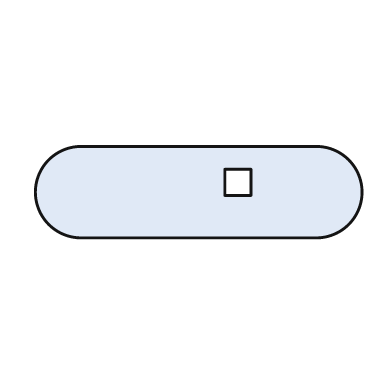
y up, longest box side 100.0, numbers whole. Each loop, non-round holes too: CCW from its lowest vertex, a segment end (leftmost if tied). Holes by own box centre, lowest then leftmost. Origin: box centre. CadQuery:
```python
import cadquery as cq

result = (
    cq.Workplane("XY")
    .moveTo(-36.0, -14.0)
    .lineTo(36.0, -14.0)
    .threePointArc((50.0, 0.0), (36.0, 14.0))
    .lineTo(-36.0, 14.0)
    .threePointArc((-50.0, 0.0), (-36.0, -14.0))
    .close()
    .moveTo(8.0, -1.0)
    .lineTo(16.0, -1.0)
    .lineTo(16.0, 7.0)
    .lineTo(8.0, 7.0)
    .close()
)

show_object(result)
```